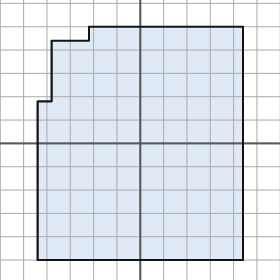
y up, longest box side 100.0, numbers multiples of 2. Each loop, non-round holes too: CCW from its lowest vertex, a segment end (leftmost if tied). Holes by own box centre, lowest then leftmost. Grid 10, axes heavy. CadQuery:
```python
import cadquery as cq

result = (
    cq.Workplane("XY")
    .moveTo(-44.0, -50.0)
    .lineTo(44.0, -50.0)
    .lineTo(44.0, 50.0)
    .lineTo(-22.0, 50.0)
    .lineTo(-22.0, 44.0)
    .lineTo(-38.0, 44.0)
    .lineTo(-38.0, 18.0)
    .lineTo(-44.0, 18.0)
    .close()
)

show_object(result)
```